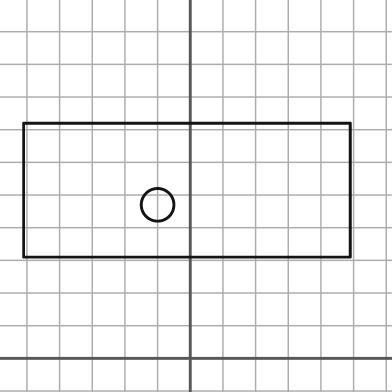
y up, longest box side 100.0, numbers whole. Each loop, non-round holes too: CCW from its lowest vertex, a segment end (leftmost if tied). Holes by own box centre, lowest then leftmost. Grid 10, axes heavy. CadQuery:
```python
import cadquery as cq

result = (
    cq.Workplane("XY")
    .moveTo(-51.0, 31.0)
    .lineTo(49.0, 31.0)
    .lineTo(49.0, 72.0)
    .lineTo(-51.0, 72.0)
    .close()
    .moveTo(-10.0, 47.0)
    .circle(5.0)
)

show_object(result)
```